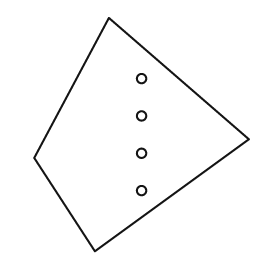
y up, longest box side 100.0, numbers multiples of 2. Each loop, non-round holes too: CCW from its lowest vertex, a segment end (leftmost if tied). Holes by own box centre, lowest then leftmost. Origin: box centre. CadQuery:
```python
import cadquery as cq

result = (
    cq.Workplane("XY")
    .moveTo(-20.0, -50.0)
    .lineTo(46.0, -2.0)
    .lineTo(-14.0, 50.0)
    .lineTo(-46.0, -10.0)
    .close()
    .moveTo(0.0, -24.0)
    .circle(2.0)
    .moveTo(0.0, -8.0)
    .circle(2.0)
    .moveTo(0.0, 8.0)
    .circle(2.0)
    .moveTo(0.0, 24.0)
    .circle(2.0)
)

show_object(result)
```